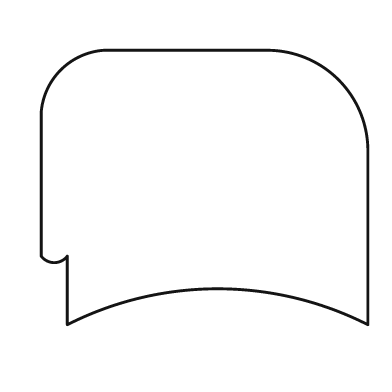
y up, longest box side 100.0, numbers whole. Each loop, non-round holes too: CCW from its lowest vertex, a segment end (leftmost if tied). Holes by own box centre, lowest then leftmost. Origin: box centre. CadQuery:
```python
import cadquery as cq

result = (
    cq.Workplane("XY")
    .moveTo(-42.0, -42.0)
    .threePointArc((4.0, -31.0), (50.0, -42.0))
    .lineTo(50.0, 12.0)
    .threePointArc((41.0, 33.0), (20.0, 42.0))
    .lineTo(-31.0, 42.0)
    .threePointArc((-44.0, 36.0), (-50.0, 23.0))
    .lineTo(-50.0, -21.0)
    .threePointArc((-46.0, -23.0), (-42.0, -21.0))
    .close()
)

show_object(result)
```